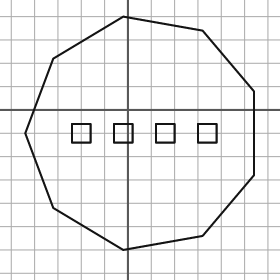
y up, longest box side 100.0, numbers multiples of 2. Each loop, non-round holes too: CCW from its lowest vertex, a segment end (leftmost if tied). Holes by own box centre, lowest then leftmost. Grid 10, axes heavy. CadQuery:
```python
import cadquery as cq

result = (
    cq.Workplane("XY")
    .moveTo(-2.0, -60.0)
    .lineTo(32.0, -54.0)
    .lineTo(54.0, -28.0)
    .lineTo(54.0, 8.0)
    .lineTo(32.0, 34.0)
    .lineTo(-2.0, 40.0)
    .lineTo(-32.0, 22.0)
    .lineTo(-44.0, -10.0)
    .lineTo(-32.0, -42.0)
    .close()
    .moveTo(-24.0, -14.0)
    .lineTo(-16.0, -14.0)
    .lineTo(-16.0, -6.0)
    .lineTo(-24.0, -6.0)
    .close()
    .moveTo(-6.0, -14.0)
    .lineTo(2.0, -14.0)
    .lineTo(2.0, -6.0)
    .lineTo(-6.0, -6.0)
    .close()
    .moveTo(12.0, -14.0)
    .lineTo(20.0, -14.0)
    .lineTo(20.0, -6.0)
    .lineTo(12.0, -6.0)
    .close()
    .moveTo(30.0, -14.0)
    .lineTo(38.0, -14.0)
    .lineTo(38.0, -6.0)
    .lineTo(30.0, -6.0)
    .close()
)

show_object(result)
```